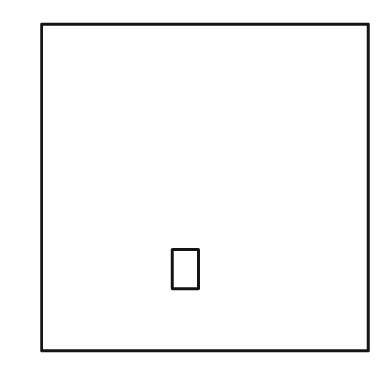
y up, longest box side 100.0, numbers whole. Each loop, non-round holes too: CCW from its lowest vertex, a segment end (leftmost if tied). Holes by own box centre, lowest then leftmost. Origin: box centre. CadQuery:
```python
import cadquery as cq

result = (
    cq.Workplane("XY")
    .moveTo(-50.0, -50.0)
    .lineTo(50.0, -50.0)
    .lineTo(50.0, 50.0)
    .lineTo(-50.0, 50.0)
    .close()
    .moveTo(-10.0, -31.0)
    .lineTo(-2.0, -31.0)
    .lineTo(-2.0, -19.0)
    .lineTo(-10.0, -19.0)
    .close()
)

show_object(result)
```